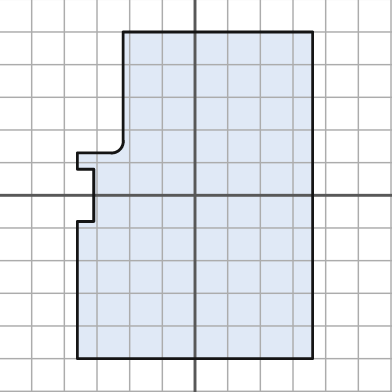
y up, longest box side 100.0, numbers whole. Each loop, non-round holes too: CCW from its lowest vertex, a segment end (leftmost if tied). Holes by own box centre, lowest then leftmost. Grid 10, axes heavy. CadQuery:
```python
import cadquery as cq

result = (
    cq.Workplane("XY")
    .moveTo(-36.0, -50.0)
    .lineTo(36.0, -50.0)
    .lineTo(36.0, 50.0)
    .lineTo(-22.0, 50.0)
    .lineTo(-22.0, 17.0)
    .threePointArc((-23.0, 14.0), (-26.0, 13.0))
    .lineTo(-36.0, 13.0)
    .lineTo(-36.0, 8.0)
    .lineTo(-31.0, 8.0)
    .lineTo(-31.0, -8.0)
    .lineTo(-36.0, -8.0)
    .close()
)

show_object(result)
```